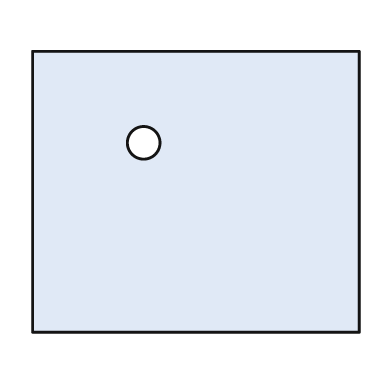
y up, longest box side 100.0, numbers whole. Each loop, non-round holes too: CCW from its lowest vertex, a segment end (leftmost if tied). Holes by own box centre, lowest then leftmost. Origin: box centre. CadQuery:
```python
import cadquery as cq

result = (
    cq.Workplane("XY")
    .moveTo(-50.0, -43.0)
    .lineTo(50.0, -43.0)
    .lineTo(50.0, 43.0)
    .lineTo(-50.0, 43.0)
    .close()
    .moveTo(-16.0, 15.0)
    .circle(5.0)
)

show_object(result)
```